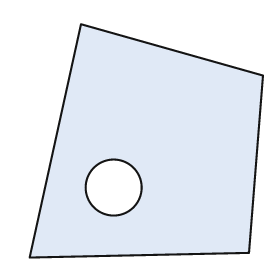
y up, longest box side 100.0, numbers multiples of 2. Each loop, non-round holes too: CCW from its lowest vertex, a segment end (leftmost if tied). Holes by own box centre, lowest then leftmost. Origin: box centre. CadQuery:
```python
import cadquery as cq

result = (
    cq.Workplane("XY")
    .moveTo(-50.0, -50.0)
    .lineTo(44.0, -48.0)
    .lineTo(50.0, 28.0)
    .lineTo(-28.0, 50.0)
    .close()
    .moveTo(-14.0, -20.0)
    .circle(12.0)
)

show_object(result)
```